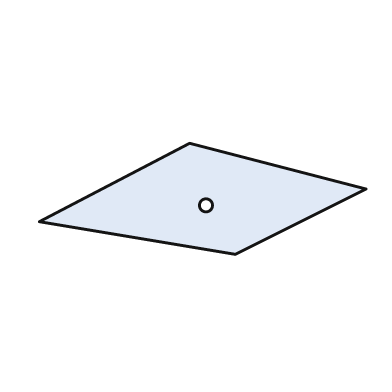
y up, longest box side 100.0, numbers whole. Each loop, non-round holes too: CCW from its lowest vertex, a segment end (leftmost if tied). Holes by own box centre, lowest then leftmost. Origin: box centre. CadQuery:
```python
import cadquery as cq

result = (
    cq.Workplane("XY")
    .moveTo(10.0, -17.0)
    .lineTo(50.0, 3.0)
    .lineTo(-4.0, 17.0)
    .lineTo(-50.0, -7.0)
    .close()
    .moveTo(1.0, -2.0)
    .circle(2.0)
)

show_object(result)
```